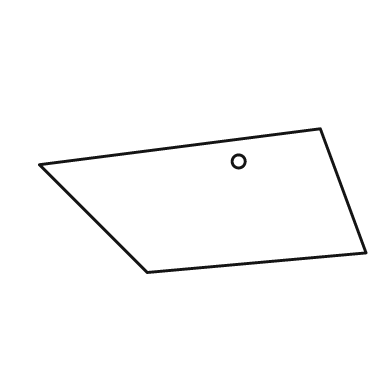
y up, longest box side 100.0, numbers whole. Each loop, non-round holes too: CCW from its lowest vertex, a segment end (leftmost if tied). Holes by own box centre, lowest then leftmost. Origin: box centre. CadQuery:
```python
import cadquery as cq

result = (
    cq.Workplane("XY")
    .moveTo(-17.0, -22.0)
    .lineTo(50.0, -16.0)
    .lineTo(36.0, 22.0)
    .lineTo(-50.0, 11.0)
    .close()
    .moveTo(11.0, 12.0)
    .circle(2.0)
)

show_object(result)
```